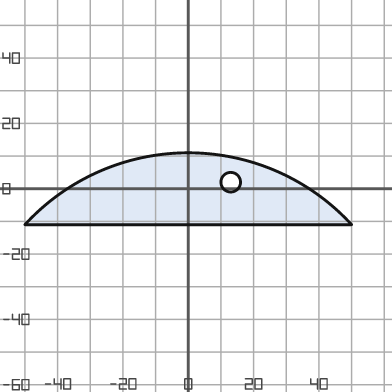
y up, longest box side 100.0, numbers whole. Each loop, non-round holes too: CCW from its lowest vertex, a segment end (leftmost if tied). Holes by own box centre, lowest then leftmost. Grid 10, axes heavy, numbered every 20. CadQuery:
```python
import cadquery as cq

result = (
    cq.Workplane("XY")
    .moveTo(-50.0, -11.0)
    .lineTo(50.0, -11.0)
    .threePointArc((0.0, 11.0), (-50.0, -11.0))
    .close()
    .moveTo(13.0, 2.0)
    .circle(3.0)
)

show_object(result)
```